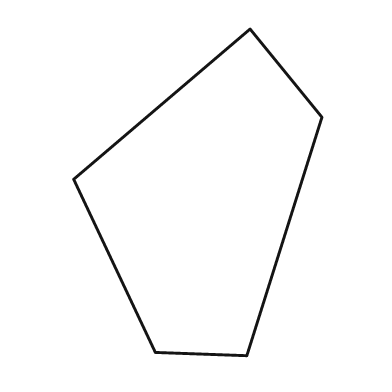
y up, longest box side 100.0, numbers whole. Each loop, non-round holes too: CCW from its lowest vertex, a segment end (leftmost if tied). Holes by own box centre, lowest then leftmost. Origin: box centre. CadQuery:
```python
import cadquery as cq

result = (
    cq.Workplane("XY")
    .moveTo(15.0, -50.0)
    .lineTo(38.0, 23.0)
    .lineTo(16.0, 50.0)
    .lineTo(-38.0, 4.0)
    .lineTo(-13.0, -49.0)
    .close()
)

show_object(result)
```